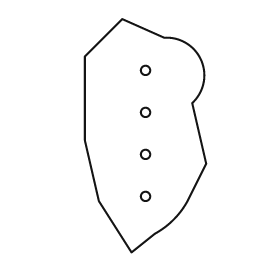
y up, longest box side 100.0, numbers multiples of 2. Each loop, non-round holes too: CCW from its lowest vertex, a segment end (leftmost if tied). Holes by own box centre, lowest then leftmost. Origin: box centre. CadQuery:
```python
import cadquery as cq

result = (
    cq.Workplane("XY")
    .moveTo(-6.0, -50.0)
    .lineTo(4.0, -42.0)
    .threePointArc((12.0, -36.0), (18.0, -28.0))
    .lineTo(26.0, -12.0)
    .lineTo(20.0, 14.0)
    .threePointArc((24.0, 32.0), (8.0, 42.0))
    .lineTo(-10.0, 50.0)
    .lineTo(-26.0, 34.0)
    .lineTo(-26.0, -2.0)
    .lineTo(-20.0, -28.0)
    .close()
    .moveTo(0.0, -26.0)
    .circle(2.0)
    .moveTo(0.0, -8.0)
    .circle(2.0)
    .moveTo(0.0, 10.0)
    .circle(2.0)
    .moveTo(0.0, 28.0)
    .circle(2.0)
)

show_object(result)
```